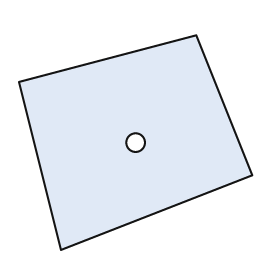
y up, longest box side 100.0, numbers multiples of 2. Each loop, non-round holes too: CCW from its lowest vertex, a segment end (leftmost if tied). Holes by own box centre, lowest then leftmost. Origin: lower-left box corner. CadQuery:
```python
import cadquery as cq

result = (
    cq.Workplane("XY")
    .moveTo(18.0, 0.0)
    .lineTo(100.0, 32.0)
    .lineTo(76.0, 92.0)
    .lineTo(0.0, 72.0)
    .close()
    .moveTo(50.0, 46.0)
    .circle(4.0)
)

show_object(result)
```